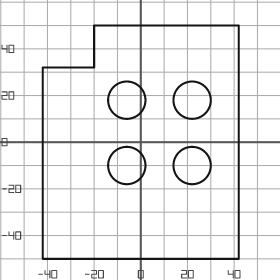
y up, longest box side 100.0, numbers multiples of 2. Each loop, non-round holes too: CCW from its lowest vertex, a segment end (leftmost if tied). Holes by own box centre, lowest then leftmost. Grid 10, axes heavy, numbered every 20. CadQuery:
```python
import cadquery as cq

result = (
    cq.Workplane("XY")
    .moveTo(-42.0, -50.0)
    .lineTo(42.0, -50.0)
    .lineTo(42.0, 50.0)
    .lineTo(-20.0, 50.0)
    .lineTo(-20.0, 32.0)
    .lineTo(-42.0, 32.0)
    .close()
    .moveTo(-6.0, -10.0)
    .circle(8.0)
    .moveTo(22.0, -10.0)
    .circle(8.0)
    .moveTo(-6.0, 18.0)
    .circle(8.0)
    .moveTo(22.0, 18.0)
    .circle(8.0)
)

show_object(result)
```